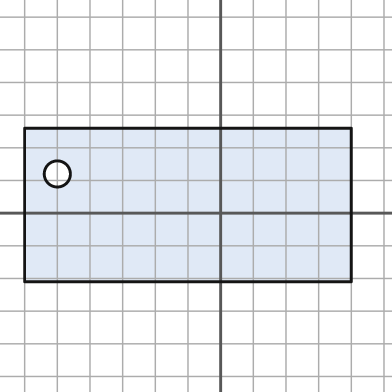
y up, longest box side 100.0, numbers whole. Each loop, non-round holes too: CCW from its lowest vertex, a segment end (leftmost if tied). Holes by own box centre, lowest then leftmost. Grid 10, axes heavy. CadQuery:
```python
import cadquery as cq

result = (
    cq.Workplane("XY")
    .moveTo(-60.0, -21.0)
    .lineTo(40.0, -21.0)
    .lineTo(40.0, 26.0)
    .lineTo(-60.0, 26.0)
    .close()
    .moveTo(-50.0, 12.0)
    .circle(4.0)
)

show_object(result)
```